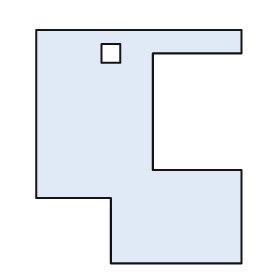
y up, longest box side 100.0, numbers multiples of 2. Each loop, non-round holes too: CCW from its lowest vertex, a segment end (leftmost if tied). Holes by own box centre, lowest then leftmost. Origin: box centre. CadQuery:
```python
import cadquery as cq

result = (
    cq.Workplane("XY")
    .moveTo(-12.0, -50.0)
    .lineTo(44.0, -50.0)
    .lineTo(44.0, -10.0)
    .lineTo(6.0, -10.0)
    .lineTo(6.0, 40.0)
    .lineTo(44.0, 40.0)
    .lineTo(44.0, 50.0)
    .lineTo(-44.0, 50.0)
    .lineTo(-44.0, -22.0)
    .lineTo(-12.0, -22.0)
    .close()
    .moveTo(-16.0, 36.0)
    .lineTo(-8.0, 36.0)
    .lineTo(-8.0, 44.0)
    .lineTo(-16.0, 44.0)
    .close()
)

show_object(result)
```